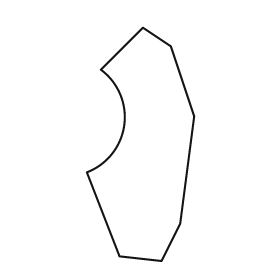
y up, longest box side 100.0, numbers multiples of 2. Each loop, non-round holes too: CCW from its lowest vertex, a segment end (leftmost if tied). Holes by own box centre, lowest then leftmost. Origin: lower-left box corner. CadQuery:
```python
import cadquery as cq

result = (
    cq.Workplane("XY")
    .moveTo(32.0, 0.0)
    .lineTo(40.0, 16.0)
    .lineTo(46.0, 62.0)
    .lineTo(36.0, 92.0)
    .lineTo(24.0, 100.0)
    .lineTo(6.0, 82.0)
    .threePointArc((16.0, 58.0), (0.0, 38.0))
    .lineTo(14.0, 2.0)
    .close()
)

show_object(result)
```